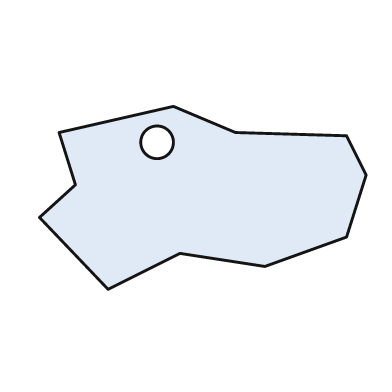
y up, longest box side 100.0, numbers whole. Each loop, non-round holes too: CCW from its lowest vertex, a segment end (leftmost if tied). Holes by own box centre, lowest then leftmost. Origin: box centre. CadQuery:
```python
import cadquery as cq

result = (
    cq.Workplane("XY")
    .moveTo(-29.0, -28.0)
    .lineTo(-7.0, -17.0)
    .lineTo(19.0, -21.0)
    .lineTo(44.0, -12.0)
    .lineTo(50.0, 7.0)
    .lineTo(44.0, 19.0)
    .lineTo(10.0, 20.0)
    .lineTo(-9.0, 28.0)
    .lineTo(-44.0, 20.0)
    .lineTo(-39.0, 4.0)
    .lineTo(-50.0, -6.0)
    .close()
    .moveTo(-14.0, 17.0)
    .circle(5.0)
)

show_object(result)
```